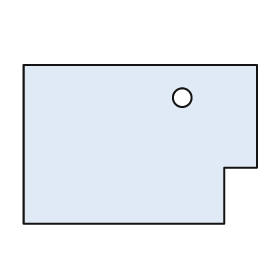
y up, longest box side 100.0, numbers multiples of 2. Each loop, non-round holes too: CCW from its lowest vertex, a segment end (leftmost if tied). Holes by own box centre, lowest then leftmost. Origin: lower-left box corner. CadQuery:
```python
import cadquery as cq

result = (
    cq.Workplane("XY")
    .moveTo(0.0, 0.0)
    .lineTo(86.0, 0.0)
    .lineTo(86.0, 24.0)
    .lineTo(100.0, 24.0)
    .lineTo(100.0, 68.0)
    .lineTo(0.0, 68.0)
    .close()
    .moveTo(68.0, 54.0)
    .circle(4.0)
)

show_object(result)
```